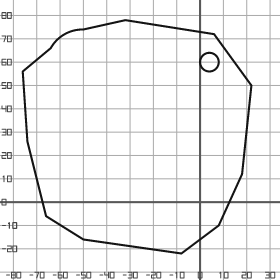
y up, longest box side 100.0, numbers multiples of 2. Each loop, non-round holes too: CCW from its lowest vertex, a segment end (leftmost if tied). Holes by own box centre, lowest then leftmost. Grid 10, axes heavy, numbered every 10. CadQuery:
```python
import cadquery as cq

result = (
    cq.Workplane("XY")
    .moveTo(-8.0, -22.0)
    .lineTo(8.0, -10.0)
    .lineTo(18.0, 12.0)
    .lineTo(22.0, 50.0)
    .lineTo(6.0, 72.0)
    .lineTo(-32.0, 78.0)
    .lineTo(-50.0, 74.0)
    .threePointArc((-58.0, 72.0), (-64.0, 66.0))
    .lineTo(-76.0, 56.0)
    .lineTo(-74.0, 26.0)
    .lineTo(-66.0, -6.0)
    .lineTo(-50.0, -16.0)
    .close()
    .moveTo(4.0, 60.0)
    .circle(4.0)
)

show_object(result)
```